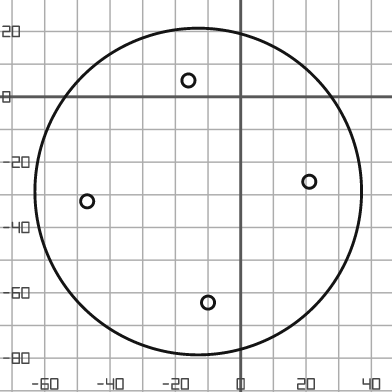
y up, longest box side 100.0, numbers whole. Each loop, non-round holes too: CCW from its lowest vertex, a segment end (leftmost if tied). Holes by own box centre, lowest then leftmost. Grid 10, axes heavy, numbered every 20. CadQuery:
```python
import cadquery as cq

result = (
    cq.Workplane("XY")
    .moveTo(-13.0, -29.0)
    .circle(50.0)
    .moveTo(-10.0, -63.0)
    .circle(2.0)
    .moveTo(-47.0, -32.0)
    .circle(2.0)
    .moveTo(21.0, -26.0)
    .circle(2.0)
    .moveTo(-16.0, 5.0)
    .circle(2.0)
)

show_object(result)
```